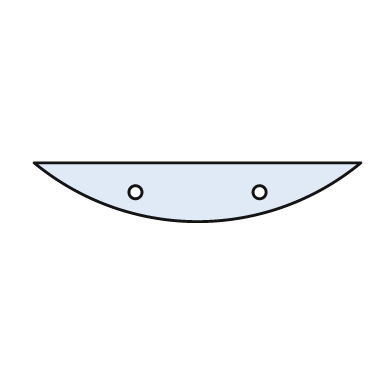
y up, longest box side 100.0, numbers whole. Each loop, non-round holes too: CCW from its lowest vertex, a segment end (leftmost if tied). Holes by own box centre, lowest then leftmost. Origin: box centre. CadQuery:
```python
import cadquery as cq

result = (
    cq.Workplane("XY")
    .moveTo(-50.0, 9.0)
    .threePointArc((0.0, -9.0), (50.0, 9.0))
    .close()
    .moveTo(-19.0, 0.0)
    .circle(2.0)
    .moveTo(19.0, 0.0)
    .circle(2.0)
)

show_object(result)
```